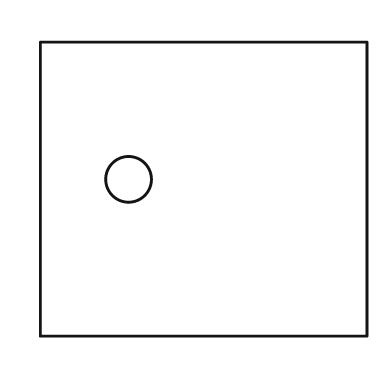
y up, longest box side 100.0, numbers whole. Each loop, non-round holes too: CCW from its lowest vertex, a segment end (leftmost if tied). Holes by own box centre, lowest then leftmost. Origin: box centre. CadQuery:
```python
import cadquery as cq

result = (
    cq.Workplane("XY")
    .moveTo(-50.0, -45.0)
    .lineTo(50.0, -45.0)
    .lineTo(50.0, 45.0)
    .lineTo(-50.0, 45.0)
    .close()
    .moveTo(-23.0, 3.0)
    .circle(7.0)
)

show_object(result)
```